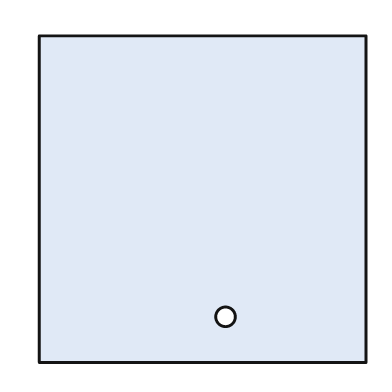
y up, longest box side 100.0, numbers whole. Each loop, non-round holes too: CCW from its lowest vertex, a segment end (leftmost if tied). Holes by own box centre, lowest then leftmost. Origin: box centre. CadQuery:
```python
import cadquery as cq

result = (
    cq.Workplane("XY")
    .moveTo(-50.0, -50.0)
    .lineTo(50.0, -50.0)
    .lineTo(50.0, 50.0)
    .lineTo(-50.0, 50.0)
    .close()
    .moveTo(7.0, -36.0)
    .circle(3.0)
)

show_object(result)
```